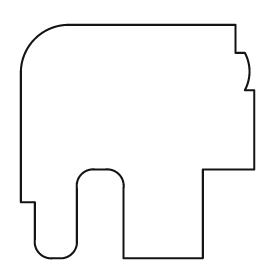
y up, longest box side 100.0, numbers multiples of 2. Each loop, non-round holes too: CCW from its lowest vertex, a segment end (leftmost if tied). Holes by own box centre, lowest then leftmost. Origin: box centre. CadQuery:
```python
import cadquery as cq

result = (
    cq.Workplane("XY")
    .moveTo(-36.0, -50.0)
    .lineTo(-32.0, -50.0)
    .threePointArc((-28.0, -48.0), (-26.0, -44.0))
    .lineTo(-26.0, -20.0)
    .threePointArc((-24.0, -14.0), (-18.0, -12.0))
    .lineTo(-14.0, -12.0)
    .threePointArc((-8.0, -14.0), (-6.0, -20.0))
    .lineTo(-6.0, -50.0)
    .lineTo(28.0, -50.0)
    .lineTo(28.0, -12.0)
    .lineTo(50.0, -12.0)
    .lineTo(50.0, 22.0)
    .lineTo(46.0, 22.0)
    .threePointArc((48.0, 30.0), (46.0, 38.0))
    .lineTo(42.0, 38.0)
    .lineTo(42.0, 50.0)
    .lineTo(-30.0, 50.0)
    .threePointArc((-44.0, 44.0), (-50.0, 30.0))
    .lineTo(-50.0, -26.0)
    .lineTo(-44.0, -26.0)
    .lineTo(-44.0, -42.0)
    .threePointArc((-42.0, -48.0), (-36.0, -50.0))
    .close()
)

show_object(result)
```